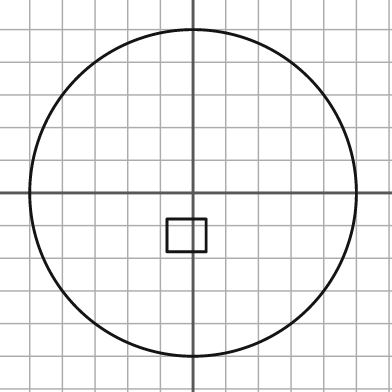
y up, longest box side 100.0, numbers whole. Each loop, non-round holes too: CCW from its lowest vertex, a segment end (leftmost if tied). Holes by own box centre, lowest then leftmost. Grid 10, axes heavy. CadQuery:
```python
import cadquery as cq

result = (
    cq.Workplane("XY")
    .moveTo(0.0, 0.0)
    .circle(50.0)
    .moveTo(-8.0, -18.0)
    .lineTo(4.0, -18.0)
    .lineTo(4.0, -8.0)
    .lineTo(-8.0, -8.0)
    .close()
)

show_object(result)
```